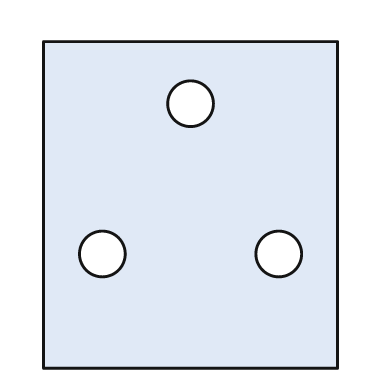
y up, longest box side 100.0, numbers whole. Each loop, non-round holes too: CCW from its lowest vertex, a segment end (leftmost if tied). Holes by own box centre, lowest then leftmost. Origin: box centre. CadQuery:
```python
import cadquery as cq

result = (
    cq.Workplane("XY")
    .moveTo(-45.0, -50.0)
    .lineTo(45.0, -50.0)
    .lineTo(45.0, 50.0)
    .lineTo(-45.0, 50.0)
    .close()
    .moveTo(-27.0, -15.0)
    .circle(7.0)
    .moveTo(27.0, -15.0)
    .circle(7.0)
    .moveTo(0.0, 31.0)
    .circle(7.0)
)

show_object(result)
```